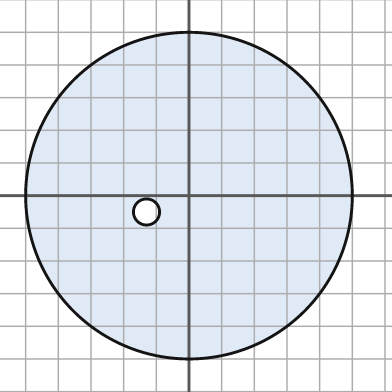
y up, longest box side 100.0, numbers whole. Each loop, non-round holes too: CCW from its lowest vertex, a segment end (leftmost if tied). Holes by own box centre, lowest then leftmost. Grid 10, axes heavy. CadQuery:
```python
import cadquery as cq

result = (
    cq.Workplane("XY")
    .moveTo(0.0, 0.0)
    .circle(50.0)
    .moveTo(-13.0, -5.0)
    .circle(4.0)
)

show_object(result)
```